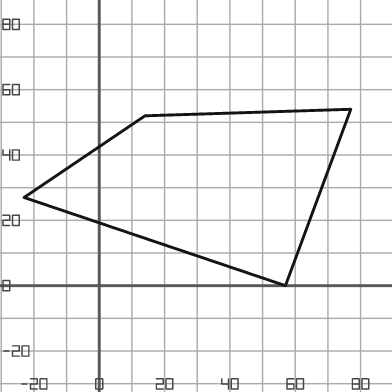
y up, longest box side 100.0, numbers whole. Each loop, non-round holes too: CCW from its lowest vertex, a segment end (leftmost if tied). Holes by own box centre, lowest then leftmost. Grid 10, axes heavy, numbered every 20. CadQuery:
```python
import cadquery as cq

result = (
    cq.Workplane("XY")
    .moveTo(57.0, 0.0)
    .lineTo(77.0, 54.0)
    .lineTo(14.0, 52.0)
    .lineTo(-23.0, 27.0)
    .close()
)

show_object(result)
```